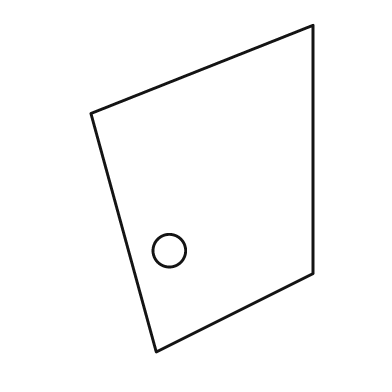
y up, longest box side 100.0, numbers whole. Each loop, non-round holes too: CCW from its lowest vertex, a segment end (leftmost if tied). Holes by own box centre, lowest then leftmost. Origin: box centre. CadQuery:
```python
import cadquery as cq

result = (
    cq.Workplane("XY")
    .moveTo(-14.0, -50.0)
    .lineTo(34.0, -26.0)
    .lineTo(34.0, 50.0)
    .lineTo(-34.0, 23.0)
    .close()
    .moveTo(-10.0, -19.0)
    .circle(5.0)
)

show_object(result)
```